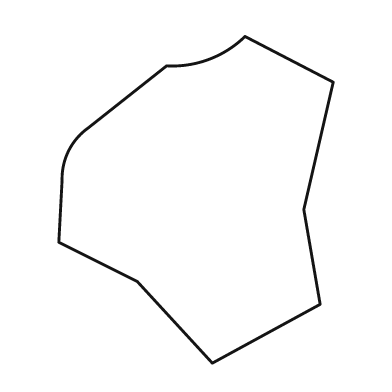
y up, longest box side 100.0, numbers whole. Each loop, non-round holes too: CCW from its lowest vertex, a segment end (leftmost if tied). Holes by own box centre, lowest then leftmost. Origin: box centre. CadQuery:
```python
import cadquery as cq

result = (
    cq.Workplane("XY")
    .moveTo(5.0, -50.0)
    .lineTo(38.0, -32.0)
    .lineTo(33.0, -3.0)
    .lineTo(42.0, 36.0)
    .lineTo(15.0, 50.0)
    .threePointArc((4.0, 43.0), (-9.0, 41.0))
    .lineTo(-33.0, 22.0)
    .threePointArc((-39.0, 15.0), (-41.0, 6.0))
    .lineTo(-42.0, -13.0)
    .lineTo(-18.0, -25.0)
    .close()
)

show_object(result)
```